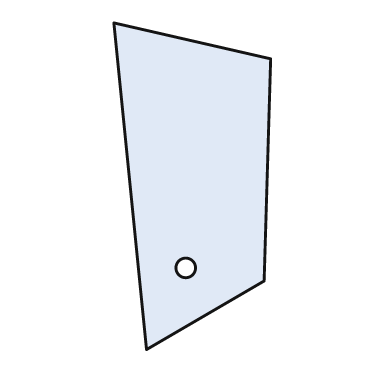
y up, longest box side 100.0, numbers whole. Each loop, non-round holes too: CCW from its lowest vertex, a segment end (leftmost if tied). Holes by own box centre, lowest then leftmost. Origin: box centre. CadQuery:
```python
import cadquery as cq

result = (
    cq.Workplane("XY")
    .moveTo(-14.0, -50.0)
    .lineTo(22.0, -29.0)
    .lineTo(24.0, 39.0)
    .lineTo(-24.0, 50.0)
    .close()
    .moveTo(-2.0, -25.0)
    .circle(3.0)
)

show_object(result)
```